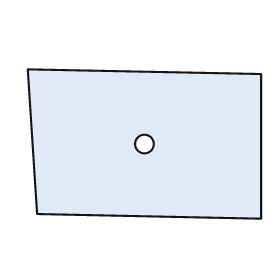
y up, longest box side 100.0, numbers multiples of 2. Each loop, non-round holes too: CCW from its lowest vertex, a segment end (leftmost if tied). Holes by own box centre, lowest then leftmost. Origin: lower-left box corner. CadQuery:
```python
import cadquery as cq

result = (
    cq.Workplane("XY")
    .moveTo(100.0, 0.0)
    .lineTo(100.0, 62.0)
    .lineTo(0.0, 64.0)
    .lineTo(4.0, 2.0)
    .close()
    .moveTo(50.0, 32.0)
    .circle(4.0)
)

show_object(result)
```